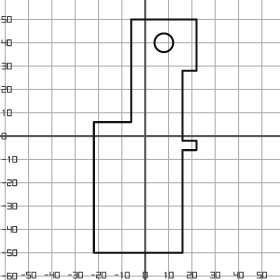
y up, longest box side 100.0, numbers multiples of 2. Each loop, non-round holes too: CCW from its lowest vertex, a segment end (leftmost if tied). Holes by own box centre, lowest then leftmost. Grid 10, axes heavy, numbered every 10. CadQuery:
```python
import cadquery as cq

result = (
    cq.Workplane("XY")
    .moveTo(-22.0, -50.0)
    .lineTo(16.0, -50.0)
    .lineTo(16.0, -6.0)
    .lineTo(22.0, -6.0)
    .lineTo(22.0, -2.0)
    .lineTo(16.0, -2.0)
    .lineTo(16.0, 28.0)
    .lineTo(22.0, 28.0)
    .lineTo(22.0, 50.0)
    .lineTo(-6.0, 50.0)
    .lineTo(-6.0, 6.0)
    .lineTo(-22.0, 6.0)
    .close()
    .moveTo(8.0, 40.0)
    .circle(4.0)
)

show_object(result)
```